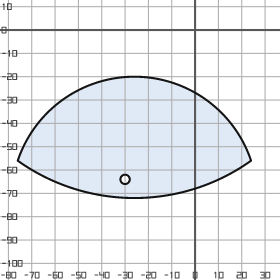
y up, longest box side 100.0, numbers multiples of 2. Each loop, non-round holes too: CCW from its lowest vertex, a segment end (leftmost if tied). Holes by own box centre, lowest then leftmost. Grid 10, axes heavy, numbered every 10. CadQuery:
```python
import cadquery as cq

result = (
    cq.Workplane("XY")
    .moveTo(-76.0, -56.0)
    .threePointArc((-26.0, -72.0), (24.0, -56.0))
    .threePointArc((-26.0, -20.0), (-76.0, -56.0))
    .close()
    .moveTo(-30.0, -64.0)
    .circle(2.0)
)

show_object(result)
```